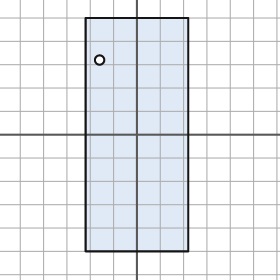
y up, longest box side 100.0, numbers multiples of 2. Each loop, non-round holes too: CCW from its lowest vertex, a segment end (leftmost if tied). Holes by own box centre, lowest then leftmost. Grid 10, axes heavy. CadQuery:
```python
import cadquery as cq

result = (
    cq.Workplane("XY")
    .moveTo(-22.0, -50.0)
    .lineTo(22.0, -50.0)
    .lineTo(22.0, 50.0)
    .lineTo(-22.0, 50.0)
    .close()
    .moveTo(-16.0, 32.0)
    .circle(2.0)
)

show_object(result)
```